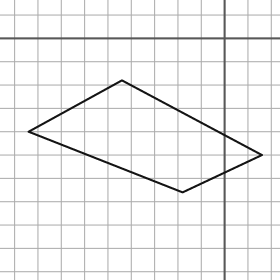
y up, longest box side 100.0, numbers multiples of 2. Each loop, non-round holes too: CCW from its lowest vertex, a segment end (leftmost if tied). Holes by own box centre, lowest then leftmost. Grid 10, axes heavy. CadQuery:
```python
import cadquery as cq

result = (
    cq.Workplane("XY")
    .moveTo(-18.0, -66.0)
    .lineTo(16.0, -50.0)
    .lineTo(-44.0, -18.0)
    .lineTo(-84.0, -40.0)
    .close()
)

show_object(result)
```